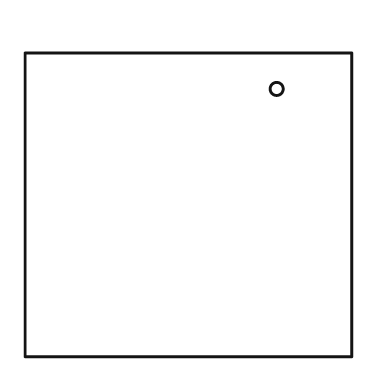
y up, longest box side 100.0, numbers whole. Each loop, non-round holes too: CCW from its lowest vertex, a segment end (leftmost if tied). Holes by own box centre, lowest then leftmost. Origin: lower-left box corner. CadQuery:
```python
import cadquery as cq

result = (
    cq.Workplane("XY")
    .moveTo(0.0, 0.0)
    .lineTo(100.0, 0.0)
    .lineTo(100.0, 93.0)
    .lineTo(0.0, 93.0)
    .close()
    .moveTo(77.0, 82.0)
    .circle(2.0)
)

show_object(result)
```